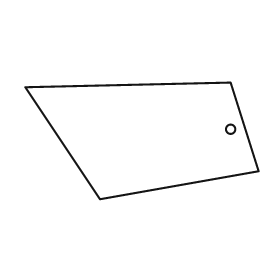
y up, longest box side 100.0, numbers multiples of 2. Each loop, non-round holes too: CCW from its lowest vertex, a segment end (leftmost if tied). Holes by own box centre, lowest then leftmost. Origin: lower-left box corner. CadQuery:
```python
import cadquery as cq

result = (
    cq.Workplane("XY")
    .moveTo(32.0, 0.0)
    .lineTo(100.0, 12.0)
    .lineTo(88.0, 50.0)
    .lineTo(0.0, 48.0)
    .close()
    .moveTo(88.0, 30.0)
    .circle(2.0)
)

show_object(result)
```